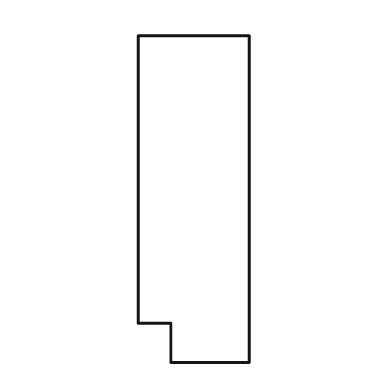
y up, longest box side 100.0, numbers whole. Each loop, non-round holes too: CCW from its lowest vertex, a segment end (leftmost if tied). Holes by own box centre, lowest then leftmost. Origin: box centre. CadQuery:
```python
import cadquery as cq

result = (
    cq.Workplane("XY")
    .moveTo(-7.0, -50.0)
    .lineTo(17.0, -50.0)
    .lineTo(17.0, 50.0)
    .lineTo(-17.0, 50.0)
    .lineTo(-17.0, -38.0)
    .lineTo(-7.0, -38.0)
    .close()
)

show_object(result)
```